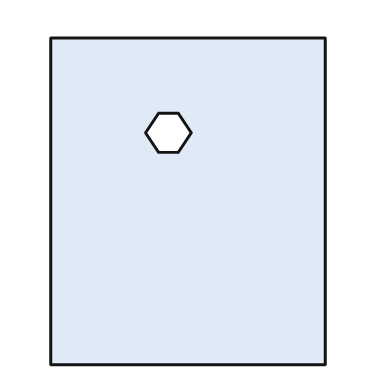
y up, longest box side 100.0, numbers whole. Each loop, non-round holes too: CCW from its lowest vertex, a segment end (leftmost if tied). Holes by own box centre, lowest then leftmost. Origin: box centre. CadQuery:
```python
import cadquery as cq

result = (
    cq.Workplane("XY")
    .moveTo(-42.0, -50.0)
    .lineTo(42.0, -50.0)
    .lineTo(42.0, 50.0)
    .lineTo(-42.0, 50.0)
    .close()
    .moveTo(-9.0, 15.0)
    .lineTo(-3.0, 15.0)
    .lineTo(1.0, 21.0)
    .lineTo(-3.0, 27.0)
    .lineTo(-9.0, 27.0)
    .lineTo(-13.0, 21.0)
    .close()
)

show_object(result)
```